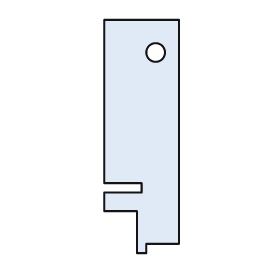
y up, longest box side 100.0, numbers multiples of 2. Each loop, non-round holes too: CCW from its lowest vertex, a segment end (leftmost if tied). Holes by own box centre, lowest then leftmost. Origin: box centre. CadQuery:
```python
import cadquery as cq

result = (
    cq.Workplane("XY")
    .moveTo(-2.0, -50.0)
    .lineTo(2.0, -50.0)
    .lineTo(2.0, -46.0)
    .lineTo(16.0, -46.0)
    .lineTo(16.0, 50.0)
    .lineTo(-16.0, 50.0)
    .lineTo(-16.0, -20.0)
    .lineTo(0.0, -20.0)
    .lineTo(0.0, -24.0)
    .lineTo(-16.0, -24.0)
    .lineTo(-16.0, -32.0)
    .lineTo(-2.0, -32.0)
    .close()
    .moveTo(6.0, 36.0)
    .circle(4.0)
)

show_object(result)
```